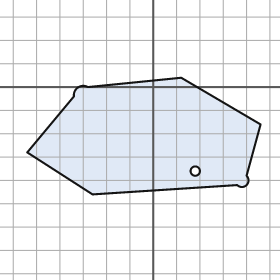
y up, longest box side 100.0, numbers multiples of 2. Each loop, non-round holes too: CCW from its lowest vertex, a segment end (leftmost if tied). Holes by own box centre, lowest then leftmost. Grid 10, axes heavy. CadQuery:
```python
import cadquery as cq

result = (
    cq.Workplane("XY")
    .moveTo(-26.0, -46.0)
    .lineTo(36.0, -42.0)
    .threePointArc((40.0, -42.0), (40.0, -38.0))
    .lineTo(46.0, -16.0)
    .lineTo(12.0, 4.0)
    .lineTo(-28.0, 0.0)
    .threePointArc((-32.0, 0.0), (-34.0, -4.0))
    .lineTo(-54.0, -28.0)
    .close()
    .moveTo(18.0, -36.0)
    .circle(2.0)
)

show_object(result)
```